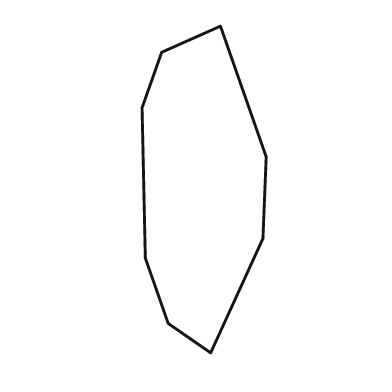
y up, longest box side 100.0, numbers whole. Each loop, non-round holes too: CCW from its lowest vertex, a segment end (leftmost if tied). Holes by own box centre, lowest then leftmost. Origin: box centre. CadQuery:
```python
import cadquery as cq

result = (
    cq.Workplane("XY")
    .moveTo(2.0, -50.0)
    .lineTo(18.0, -15.0)
    .lineTo(19.0, 10.0)
    .lineTo(5.0, 50.0)
    .lineTo(-13.0, 42.0)
    .lineTo(-19.0, 25.0)
    .lineTo(-18.0, -21.0)
    .lineTo(-11.0, -41.0)
    .close()
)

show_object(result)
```